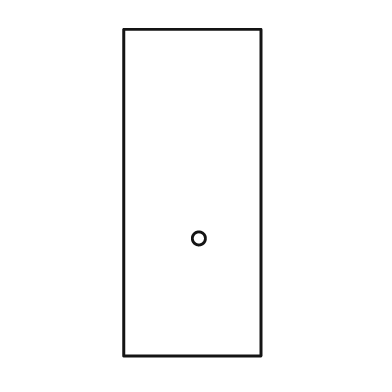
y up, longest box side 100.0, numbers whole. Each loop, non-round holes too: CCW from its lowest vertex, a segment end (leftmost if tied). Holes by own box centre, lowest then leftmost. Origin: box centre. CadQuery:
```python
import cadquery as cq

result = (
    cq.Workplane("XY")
    .moveTo(-21.0, -50.0)
    .lineTo(21.0, -50.0)
    .lineTo(21.0, 50.0)
    .lineTo(-21.0, 50.0)
    .close()
    .moveTo(2.0, -14.0)
    .circle(2.0)
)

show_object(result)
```